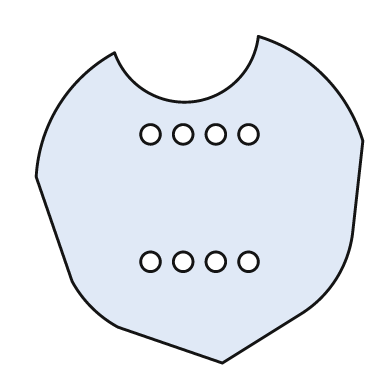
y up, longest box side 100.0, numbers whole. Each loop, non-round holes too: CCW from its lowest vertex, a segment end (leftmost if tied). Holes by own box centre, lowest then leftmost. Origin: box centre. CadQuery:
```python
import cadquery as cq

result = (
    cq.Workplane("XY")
    .moveTo(7.0, -50.0)
    .lineTo(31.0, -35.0)
    .threePointArc((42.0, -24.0), (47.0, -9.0))
    .lineTo(50.0, 18.0)
    .threePointArc((38.0, 38.0), (18.0, 50.0))
    .threePointArc((-2.0, 30.0), (-26.0, 45.0))
    .threePointArc((-43.0, 29.0), (-50.0, 7.0))
    .lineTo(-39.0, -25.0)
    .threePointArc((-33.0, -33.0), (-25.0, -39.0))
    .close()
    .moveTo(-15.0, -19.0)
    .circle(3.0)
    .moveTo(-5.0, -19.0)
    .circle(3.0)
    .moveTo(5.0, -19.0)
    .circle(3.0)
    .moveTo(15.0, -19.0)
    .circle(3.0)
    .moveTo(-15.0, 20.0)
    .circle(3.0)
    .moveTo(-5.0, 20.0)
    .circle(3.0)
    .moveTo(5.0, 20.0)
    .circle(3.0)
    .moveTo(15.0, 20.0)
    .circle(3.0)
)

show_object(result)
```